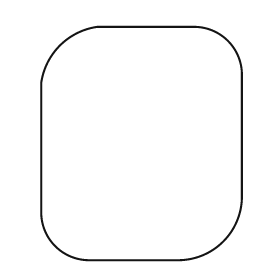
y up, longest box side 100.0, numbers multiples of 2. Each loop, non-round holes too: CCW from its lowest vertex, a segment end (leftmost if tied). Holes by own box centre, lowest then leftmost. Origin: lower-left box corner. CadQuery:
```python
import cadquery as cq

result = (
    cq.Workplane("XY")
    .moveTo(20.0, 0.0)
    .lineTo(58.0, 0.0)
    .threePointArc((78.0, 8.0), (86.0, 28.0))
    .lineTo(86.0, 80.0)
    .threePointArc((80.0, 94.0), (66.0, 100.0))
    .lineTo(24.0, 100.0)
    .threePointArc((8.0, 92.0), (0.0, 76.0))
    .lineTo(0.0, 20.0)
    .threePointArc((6.0, 6.0), (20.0, 0.0))
    .close()
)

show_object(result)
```